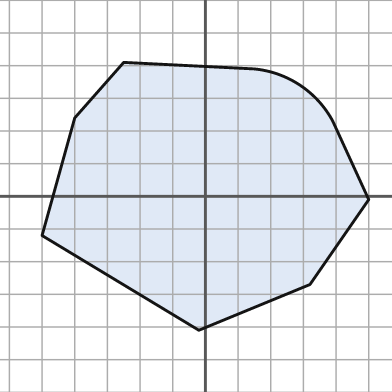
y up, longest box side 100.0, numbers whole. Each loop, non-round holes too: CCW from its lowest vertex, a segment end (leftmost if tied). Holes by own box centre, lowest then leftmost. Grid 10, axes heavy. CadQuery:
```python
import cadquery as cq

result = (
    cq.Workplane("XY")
    .moveTo(-2.0, -41.0)
    .lineTo(32.0, -27.0)
    .lineTo(50.0, -1.0)
    .lineTo(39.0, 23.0)
    .threePointArc((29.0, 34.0), (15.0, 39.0))
    .lineTo(-25.0, 41.0)
    .lineTo(-40.0, 24.0)
    .lineTo(-50.0, -12.0)
    .close()
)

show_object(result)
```